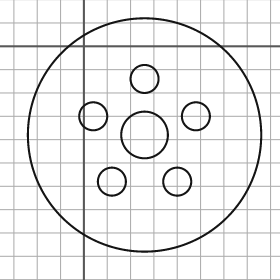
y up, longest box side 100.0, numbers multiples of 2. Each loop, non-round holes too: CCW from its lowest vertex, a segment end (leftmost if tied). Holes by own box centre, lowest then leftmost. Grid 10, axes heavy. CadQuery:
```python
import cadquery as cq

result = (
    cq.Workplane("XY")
    .moveTo(26.0, -38.0)
    .circle(50.0)
    .moveTo(12.0, -58.0)
    .circle(6.0)
    .moveTo(40.0, -58.0)
    .circle(6.0)
    .moveTo(26.0, -38.0)
    .circle(10.0)
    .moveTo(4.0, -30.0)
    .circle(6.0)
    .moveTo(48.0, -30.0)
    .circle(6.0)
    .moveTo(26.0, -14.0)
    .circle(6.0)
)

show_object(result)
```